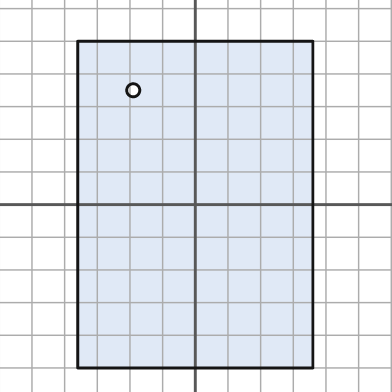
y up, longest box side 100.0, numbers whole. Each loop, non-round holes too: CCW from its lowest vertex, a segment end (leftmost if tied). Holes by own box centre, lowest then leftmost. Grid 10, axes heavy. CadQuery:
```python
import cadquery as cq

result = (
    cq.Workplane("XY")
    .moveTo(-36.0, -50.0)
    .lineTo(36.0, -50.0)
    .lineTo(36.0, 50.0)
    .lineTo(-36.0, 50.0)
    .close()
    .moveTo(-19.0, 35.0)
    .circle(2.0)
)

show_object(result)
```